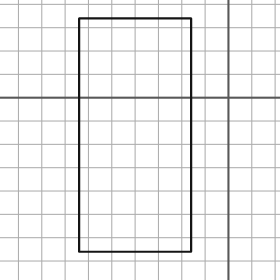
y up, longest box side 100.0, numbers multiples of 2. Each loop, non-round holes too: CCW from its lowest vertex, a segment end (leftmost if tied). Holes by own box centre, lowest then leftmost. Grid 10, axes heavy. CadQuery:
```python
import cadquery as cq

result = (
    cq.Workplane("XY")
    .moveTo(-64.0, -66.0)
    .lineTo(-16.0, -66.0)
    .lineTo(-16.0, 34.0)
    .lineTo(-64.0, 34.0)
    .close()
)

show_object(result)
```